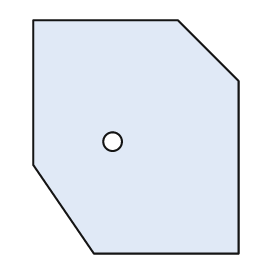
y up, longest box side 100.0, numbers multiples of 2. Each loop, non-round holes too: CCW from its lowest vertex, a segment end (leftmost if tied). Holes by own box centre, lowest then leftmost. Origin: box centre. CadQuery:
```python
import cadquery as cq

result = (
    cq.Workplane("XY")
    .moveTo(-18.0, -50.0)
    .lineTo(44.0, -50.0)
    .lineTo(44.0, 24.0)
    .lineTo(18.0, 50.0)
    .lineTo(-44.0, 50.0)
    .lineTo(-44.0, -12.0)
    .close()
    .moveTo(-10.0, -2.0)
    .circle(4.0)
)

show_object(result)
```